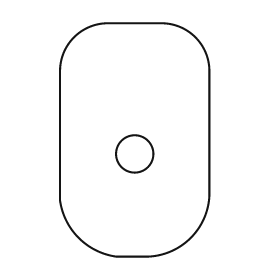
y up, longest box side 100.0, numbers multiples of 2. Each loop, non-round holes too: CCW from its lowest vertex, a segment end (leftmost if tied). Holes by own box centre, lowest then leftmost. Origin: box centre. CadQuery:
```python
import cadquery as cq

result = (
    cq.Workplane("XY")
    .moveTo(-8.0, -50.0)
    .lineTo(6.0, -50.0)
    .threePointArc((24.0, -42.0), (32.0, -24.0))
    .lineTo(32.0, 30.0)
    .threePointArc((26.0, 44.0), (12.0, 50.0))
    .lineTo(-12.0, 50.0)
    .threePointArc((-26.0, 44.0), (-32.0, 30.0))
    .lineTo(-32.0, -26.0)
    .threePointArc((-24.0, -42.0), (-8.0, -50.0))
    .close()
    .moveTo(0.0, -6.0)
    .circle(8.0)
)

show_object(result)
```